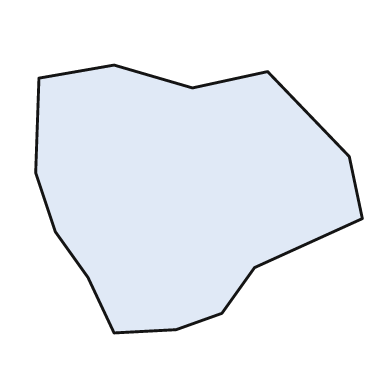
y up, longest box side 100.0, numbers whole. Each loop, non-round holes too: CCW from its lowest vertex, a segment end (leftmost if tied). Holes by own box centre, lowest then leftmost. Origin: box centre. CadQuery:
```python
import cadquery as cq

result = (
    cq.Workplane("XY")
    .moveTo(-26.0, -41.0)
    .lineTo(-7.0, -40.0)
    .lineTo(7.0, -35.0)
    .lineTo(17.0, -21.0)
    .lineTo(50.0, -6.0)
    .lineTo(46.0, 13.0)
    .lineTo(21.0, 39.0)
    .lineTo(-2.0, 34.0)
    .lineTo(-26.0, 41.0)
    .lineTo(-49.0, 37.0)
    .lineTo(-50.0, 8.0)
    .lineTo(-44.0, -10.0)
    .lineTo(-34.0, -24.0)
    .close()
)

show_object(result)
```